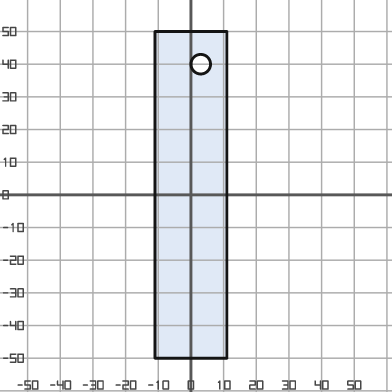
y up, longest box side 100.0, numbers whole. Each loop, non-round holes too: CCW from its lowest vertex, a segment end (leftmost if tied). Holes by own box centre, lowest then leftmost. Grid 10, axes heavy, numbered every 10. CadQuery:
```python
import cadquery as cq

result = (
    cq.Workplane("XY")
    .moveTo(-11.0, -50.0)
    .lineTo(11.0, -50.0)
    .lineTo(11.0, 50.0)
    .lineTo(-11.0, 50.0)
    .close()
    .moveTo(3.0, 40.0)
    .circle(3.0)
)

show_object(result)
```